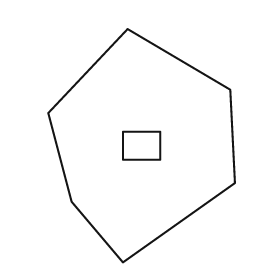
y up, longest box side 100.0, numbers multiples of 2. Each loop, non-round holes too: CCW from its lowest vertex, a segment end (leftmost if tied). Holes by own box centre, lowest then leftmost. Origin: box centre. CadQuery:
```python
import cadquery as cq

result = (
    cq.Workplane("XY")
    .moveTo(-8.0, -50.0)
    .lineTo(40.0, -16.0)
    .lineTo(38.0, 24.0)
    .lineTo(-6.0, 50.0)
    .lineTo(-40.0, 14.0)
    .lineTo(-30.0, -24.0)
    .close()
    .moveTo(-8.0, -6.0)
    .lineTo(8.0, -6.0)
    .lineTo(8.0, 6.0)
    .lineTo(-8.0, 6.0)
    .close()
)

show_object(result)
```